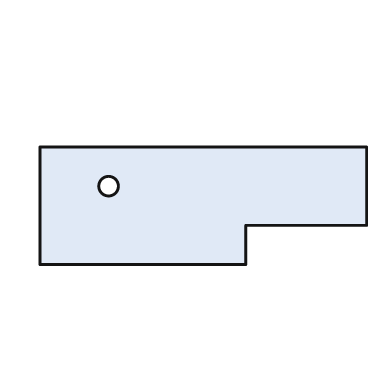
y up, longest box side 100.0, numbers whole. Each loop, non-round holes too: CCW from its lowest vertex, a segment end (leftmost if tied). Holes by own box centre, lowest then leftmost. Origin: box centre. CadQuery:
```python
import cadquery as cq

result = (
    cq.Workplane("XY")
    .moveTo(-50.0, -18.0)
    .lineTo(13.0, -18.0)
    .lineTo(13.0, -6.0)
    .lineTo(50.0, -6.0)
    .lineTo(50.0, 18.0)
    .lineTo(-50.0, 18.0)
    .close()
    .moveTo(-29.0, 6.0)
    .circle(3.0)
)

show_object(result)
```